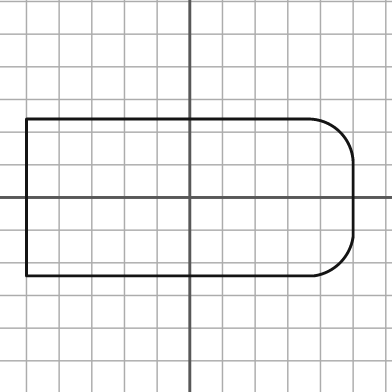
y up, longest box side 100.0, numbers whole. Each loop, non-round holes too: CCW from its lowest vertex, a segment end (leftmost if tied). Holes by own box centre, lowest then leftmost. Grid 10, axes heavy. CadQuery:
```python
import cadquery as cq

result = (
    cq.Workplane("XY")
    .moveTo(-50.0, -24.0)
    .lineTo(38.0, -24.0)
    .threePointArc((46.0, -20.0), (50.0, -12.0))
    .lineTo(50.0, 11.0)
    .threePointArc((46.0, 20.0), (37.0, 24.0))
    .lineTo(-50.0, 24.0)
    .close()
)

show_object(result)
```